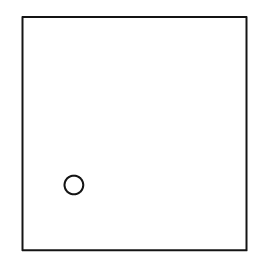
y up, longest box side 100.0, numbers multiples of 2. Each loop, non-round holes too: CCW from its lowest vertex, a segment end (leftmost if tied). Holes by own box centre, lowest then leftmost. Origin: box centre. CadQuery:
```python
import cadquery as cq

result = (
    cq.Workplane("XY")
    .moveTo(-48.0, -50.0)
    .lineTo(48.0, -50.0)
    .lineTo(48.0, 50.0)
    .lineTo(-48.0, 50.0)
    .close()
    .moveTo(-26.0, -22.0)
    .circle(4.0)
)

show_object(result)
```